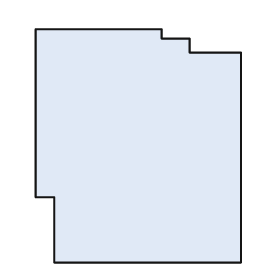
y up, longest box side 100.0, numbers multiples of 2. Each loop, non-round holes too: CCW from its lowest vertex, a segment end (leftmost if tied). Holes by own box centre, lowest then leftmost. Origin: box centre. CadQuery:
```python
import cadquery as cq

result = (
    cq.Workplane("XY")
    .moveTo(-36.0, -50.0)
    .lineTo(44.0, -50.0)
    .lineTo(44.0, 40.0)
    .lineTo(22.0, 40.0)
    .lineTo(22.0, 46.0)
    .lineTo(10.0, 46.0)
    .lineTo(10.0, 50.0)
    .lineTo(-44.0, 50.0)
    .lineTo(-44.0, -22.0)
    .lineTo(-36.0, -22.0)
    .close()
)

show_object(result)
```